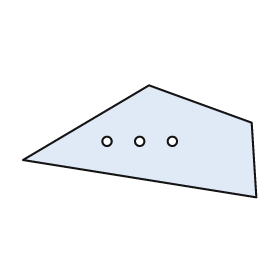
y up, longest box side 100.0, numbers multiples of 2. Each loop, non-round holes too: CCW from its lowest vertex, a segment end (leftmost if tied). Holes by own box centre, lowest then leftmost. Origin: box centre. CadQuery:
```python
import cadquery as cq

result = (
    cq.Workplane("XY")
    .moveTo(50.0, -24.0)
    .lineTo(48.0, 8.0)
    .lineTo(4.0, 24.0)
    .lineTo(-50.0, -8.0)
    .close()
    .moveTo(-14.0, 0.0)
    .circle(2.0)
    .moveTo(0.0, 0.0)
    .circle(2.0)
    .moveTo(14.0, 0.0)
    .circle(2.0)
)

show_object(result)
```